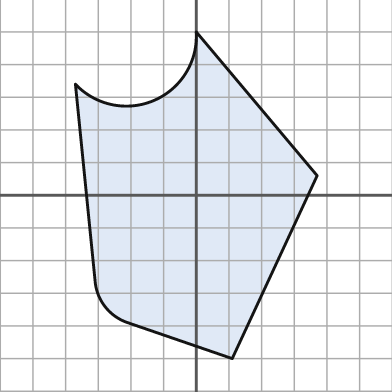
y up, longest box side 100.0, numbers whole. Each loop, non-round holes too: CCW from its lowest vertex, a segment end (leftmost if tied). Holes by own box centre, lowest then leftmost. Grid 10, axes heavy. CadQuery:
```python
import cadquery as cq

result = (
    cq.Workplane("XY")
    .moveTo(11.0, -50.0)
    .lineTo(37.0, 6.0)
    .lineTo(0.0, 50.0)
    .threePointArc((-13.0, 29.0), (-37.0, 34.0))
    .lineTo(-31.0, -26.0)
    .threePointArc((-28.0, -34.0), (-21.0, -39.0))
    .close()
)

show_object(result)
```